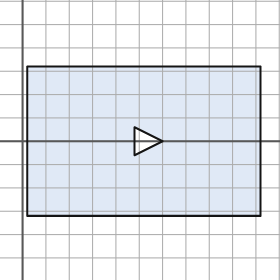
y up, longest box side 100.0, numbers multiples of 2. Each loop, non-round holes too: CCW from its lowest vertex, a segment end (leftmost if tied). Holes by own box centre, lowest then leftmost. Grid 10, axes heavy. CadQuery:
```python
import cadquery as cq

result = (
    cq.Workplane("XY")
    .moveTo(2.0, -32.0)
    .lineTo(102.0, -32.0)
    .lineTo(102.0, 32.0)
    .lineTo(2.0, 32.0)
    .close()
    .moveTo(48.0, -6.0)
    .lineTo(60.0, 0.0)
    .lineTo(48.0, 6.0)
    .close()
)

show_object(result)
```